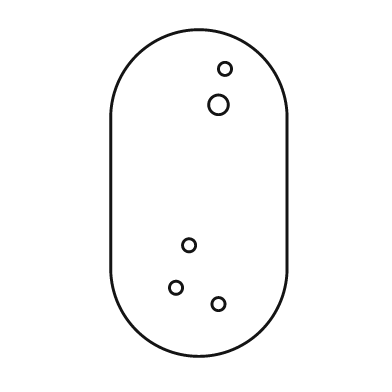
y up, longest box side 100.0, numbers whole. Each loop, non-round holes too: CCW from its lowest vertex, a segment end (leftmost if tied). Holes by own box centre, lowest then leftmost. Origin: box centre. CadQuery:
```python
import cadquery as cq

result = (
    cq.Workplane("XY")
    .moveTo(-27.0, -23.0)
    .threePointArc((0.0, -50.0), (27.0, -23.0))
    .lineTo(27.0, 23.0)
    .threePointArc((0.0, 50.0), (-27.0, 23.0))
    .close()
    .moveTo(6.0, -34.0)
    .circle(2.0)
    .moveTo(-7.0, -29.0)
    .circle(2.0)
    .moveTo(-3.0, -16.0)
    .circle(2.0)
    .moveTo(6.0, 27.0)
    .circle(3.0)
    .moveTo(8.0, 38.0)
    .circle(2.0)
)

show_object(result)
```